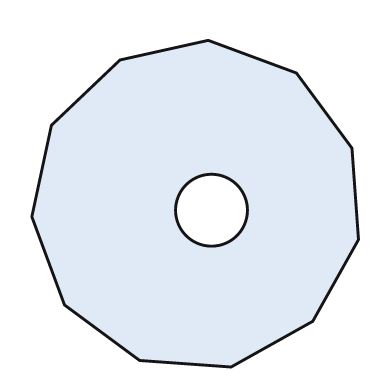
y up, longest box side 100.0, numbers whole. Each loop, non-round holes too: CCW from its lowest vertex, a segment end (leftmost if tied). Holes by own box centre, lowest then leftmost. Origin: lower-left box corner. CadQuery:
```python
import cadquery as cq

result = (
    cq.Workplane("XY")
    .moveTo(61.0, 0.0)
    .lineTo(86.0, 14.0)
    .lineTo(100.0, 39.0)
    .lineTo(98.0, 67.0)
    .lineTo(81.0, 90.0)
    .lineTo(54.0, 100.0)
    .lineTo(27.0, 94.0)
    .lineTo(6.0, 74.0)
    .lineTo(0.0, 46.0)
    .lineTo(10.0, 19.0)
    .lineTo(33.0, 2.0)
    .close()
    .moveTo(55.0, 48.0)
    .circle(11.0)
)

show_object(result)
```